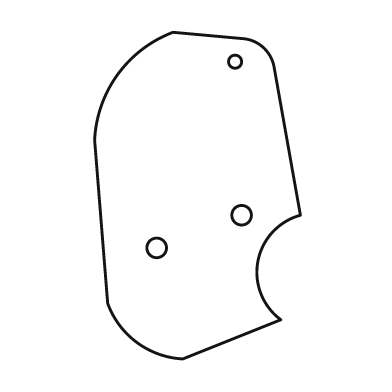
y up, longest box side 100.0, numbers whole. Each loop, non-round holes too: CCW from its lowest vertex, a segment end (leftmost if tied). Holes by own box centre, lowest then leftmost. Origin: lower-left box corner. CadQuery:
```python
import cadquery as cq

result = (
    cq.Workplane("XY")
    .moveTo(27.0, 0.0)
    .lineTo(57.0, 12.0)
    .threePointArc((50.0, 30.0), (63.0, 44.0))
    .lineTo(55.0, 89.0)
    .threePointArc((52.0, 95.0), (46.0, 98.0))
    .lineTo(24.0, 100.0)
    .threePointArc((7.0, 87.0), (0.0, 67.0))
    .lineTo(4.0, 17.0)
    .threePointArc((13.0, 5.0), (27.0, 0.0))
    .close()
    .moveTo(19.0, 34.0)
    .circle(3.0)
    .moveTo(45.0, 44.0)
    .circle(3.0)
    .moveTo(43.0, 91.0)
    .circle(2.0)
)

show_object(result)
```